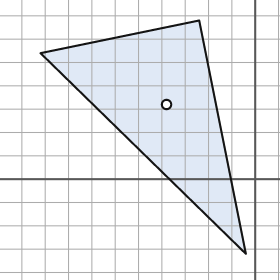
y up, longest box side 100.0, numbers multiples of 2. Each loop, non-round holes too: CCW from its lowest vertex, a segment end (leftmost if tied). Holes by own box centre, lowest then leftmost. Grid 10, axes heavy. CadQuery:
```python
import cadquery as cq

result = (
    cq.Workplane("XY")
    .moveTo(-4.0, -32.0)
    .lineTo(-24.0, 68.0)
    .lineTo(-92.0, 54.0)
    .close()
    .moveTo(-38.0, 32.0)
    .circle(2.0)
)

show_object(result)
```